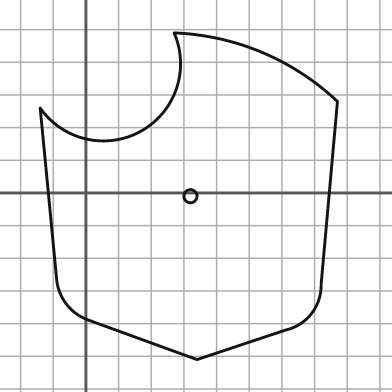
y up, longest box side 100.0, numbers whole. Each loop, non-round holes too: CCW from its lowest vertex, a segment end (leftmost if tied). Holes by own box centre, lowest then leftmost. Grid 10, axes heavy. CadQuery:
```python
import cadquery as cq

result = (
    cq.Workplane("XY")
    .moveTo(34.0, -51.0)
    .lineTo(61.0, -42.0)
    .threePointArc((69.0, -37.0), (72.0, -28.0))
    .lineTo(77.0, 28.0)
    .threePointArc((54.0, 43.0), (27.0, 49.0))
    .threePointArc((17.0, 19.0), (-14.0, 26.0))
    .lineTo(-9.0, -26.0)
    .threePointArc((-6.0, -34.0), (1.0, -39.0))
    .close()
    .moveTo(32.0, -1.0)
    .circle(2.0)
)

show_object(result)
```